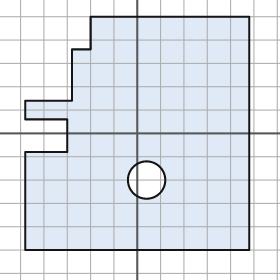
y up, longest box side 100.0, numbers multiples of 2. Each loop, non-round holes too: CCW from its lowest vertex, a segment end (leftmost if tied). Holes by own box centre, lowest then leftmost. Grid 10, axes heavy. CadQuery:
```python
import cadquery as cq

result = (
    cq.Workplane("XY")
    .moveTo(-48.0, -50.0)
    .lineTo(48.0, -50.0)
    .lineTo(48.0, 50.0)
    .lineTo(-20.0, 50.0)
    .lineTo(-20.0, 36.0)
    .lineTo(-28.0, 36.0)
    .lineTo(-28.0, 14.0)
    .lineTo(-48.0, 14.0)
    .lineTo(-48.0, 6.0)
    .lineTo(-30.0, 6.0)
    .lineTo(-30.0, -8.0)
    .lineTo(-48.0, -8.0)
    .close()
    .moveTo(4.0, -20.0)
    .circle(8.0)
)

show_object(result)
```